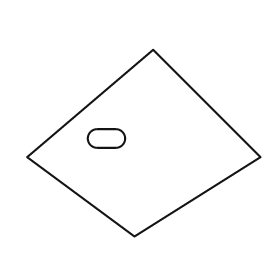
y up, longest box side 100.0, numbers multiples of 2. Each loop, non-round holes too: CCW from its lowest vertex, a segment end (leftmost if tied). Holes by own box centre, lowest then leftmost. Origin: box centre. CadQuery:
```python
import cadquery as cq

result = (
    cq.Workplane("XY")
    .moveTo(-4.0, -40.0)
    .lineTo(50.0, -6.0)
    .lineTo(4.0, 40.0)
    .lineTo(-50.0, -6.0)
    .close()
    .moveTo(-20.0, -2.0)
    .lineTo(-12.0, -2.0)
    .threePointArc((-8.0, 2.0), (-12.0, 6.0))
    .lineTo(-20.0, 6.0)
    .threePointArc((-24.0, 2.0), (-20.0, -2.0))
    .close()
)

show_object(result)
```